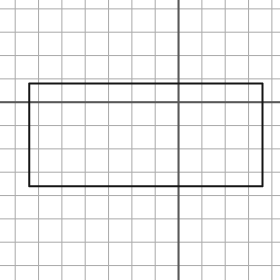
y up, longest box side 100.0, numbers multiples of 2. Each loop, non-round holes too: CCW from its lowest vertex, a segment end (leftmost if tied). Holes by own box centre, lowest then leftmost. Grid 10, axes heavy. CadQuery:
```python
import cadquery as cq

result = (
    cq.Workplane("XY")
    .moveTo(-64.0, -36.0)
    .lineTo(36.0, -36.0)
    .lineTo(36.0, 8.0)
    .lineTo(-64.0, 8.0)
    .close()
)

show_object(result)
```